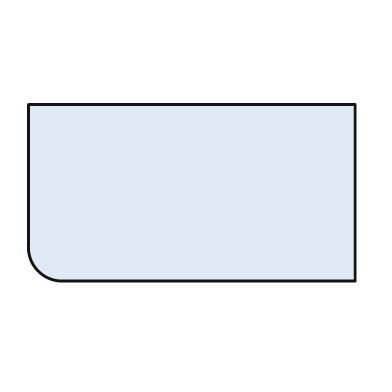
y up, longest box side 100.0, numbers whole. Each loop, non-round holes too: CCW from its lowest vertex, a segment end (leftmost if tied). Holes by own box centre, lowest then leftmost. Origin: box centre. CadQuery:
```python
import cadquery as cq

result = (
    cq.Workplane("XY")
    .moveTo(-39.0, -27.0)
    .lineTo(50.0, -27.0)
    .lineTo(50.0, 27.0)
    .lineTo(-50.0, 27.0)
    .lineTo(-50.0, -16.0)
    .threePointArc((-47.0, -24.0), (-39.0, -27.0))
    .close()
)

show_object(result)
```